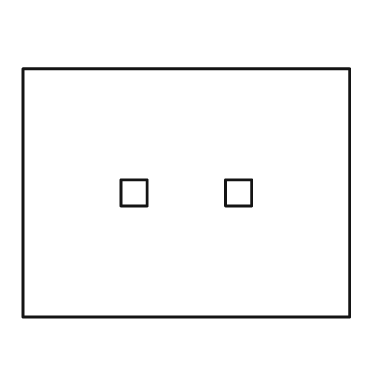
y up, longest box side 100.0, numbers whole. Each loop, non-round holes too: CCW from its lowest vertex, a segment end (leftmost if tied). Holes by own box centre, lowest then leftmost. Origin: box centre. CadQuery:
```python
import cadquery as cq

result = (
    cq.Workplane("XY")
    .moveTo(-50.0, -38.0)
    .lineTo(50.0, -38.0)
    .lineTo(50.0, 38.0)
    .lineTo(-50.0, 38.0)
    .close()
    .moveTo(-20.0, -4.0)
    .lineTo(-12.0, -4.0)
    .lineTo(-12.0, 4.0)
    .lineTo(-20.0, 4.0)
    .close()
    .moveTo(12.0, -4.0)
    .lineTo(20.0, -4.0)
    .lineTo(20.0, 4.0)
    .lineTo(12.0, 4.0)
    .close()
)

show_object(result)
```